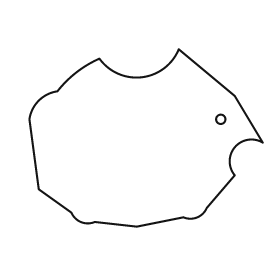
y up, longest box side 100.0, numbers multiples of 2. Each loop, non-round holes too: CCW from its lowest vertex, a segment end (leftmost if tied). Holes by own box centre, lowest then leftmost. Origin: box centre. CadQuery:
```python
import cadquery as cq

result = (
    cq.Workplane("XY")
    .moveTo(-4.0, -38.0)
    .lineTo(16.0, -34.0)
    .threePointArc((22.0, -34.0), (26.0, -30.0))
    .lineTo(38.0, -16.0)
    .threePointArc((38.0, -4.0), (50.0, -2.0))
    .lineTo(38.0, 18.0)
    .lineTo(14.0, 38.0)
    .threePointArc((-2.0, 26.0), (-20.0, 34.0))
    .threePointArc((-30.0, 28.0), (-38.0, 20.0))
    .threePointArc((-46.0, 16.0), (-50.0, 8.0))
    .lineTo(-46.0, -22.0)
    .lineTo(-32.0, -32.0)
    .threePointArc((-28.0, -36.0), (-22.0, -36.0))
    .close()
    .moveTo(32.0, 8.0)
    .circle(2.0)
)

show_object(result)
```